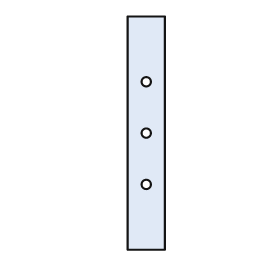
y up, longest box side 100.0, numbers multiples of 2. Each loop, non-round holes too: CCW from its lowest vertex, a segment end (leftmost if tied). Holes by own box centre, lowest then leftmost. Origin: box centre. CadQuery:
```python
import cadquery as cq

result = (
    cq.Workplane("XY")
    .moveTo(-8.0, -50.0)
    .lineTo(8.0, -50.0)
    .lineTo(8.0, 50.0)
    .lineTo(-8.0, 50.0)
    .close()
    .moveTo(0.0, -22.0)
    .circle(2.0)
    .moveTo(0.0, 0.0)
    .circle(2.0)
    .moveTo(0.0, 22.0)
    .circle(2.0)
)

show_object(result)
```